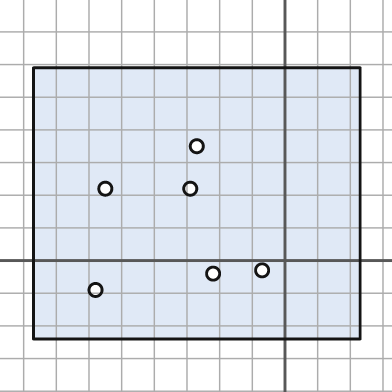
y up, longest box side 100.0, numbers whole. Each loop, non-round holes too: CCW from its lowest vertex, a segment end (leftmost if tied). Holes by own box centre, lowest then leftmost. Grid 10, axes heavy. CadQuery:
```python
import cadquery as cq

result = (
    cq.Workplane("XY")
    .moveTo(-77.0, -24.0)
    .lineTo(23.0, -24.0)
    .lineTo(23.0, 59.0)
    .lineTo(-77.0, 59.0)
    .close()
    .moveTo(-58.0, -9.0)
    .circle(2.0)
    .moveTo(-22.0, -4.0)
    .circle(2.0)
    .moveTo(-7.0, -3.0)
    .circle(2.0)
    .moveTo(-55.0, 22.0)
    .circle(2.0)
    .moveTo(-29.0, 22.0)
    .circle(2.0)
    .moveTo(-27.0, 35.0)
    .circle(2.0)
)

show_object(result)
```